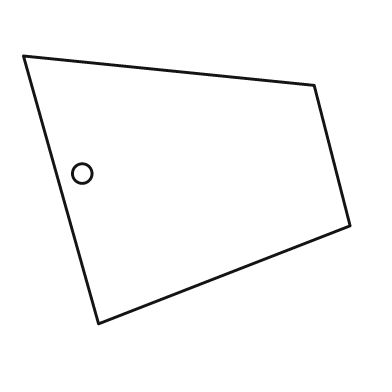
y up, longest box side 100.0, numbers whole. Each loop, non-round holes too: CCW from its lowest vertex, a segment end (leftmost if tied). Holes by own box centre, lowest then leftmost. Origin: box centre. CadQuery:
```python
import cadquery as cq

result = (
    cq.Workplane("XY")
    .moveTo(-27.0, -41.0)
    .lineTo(50.0, -11.0)
    .lineTo(39.0, 32.0)
    .lineTo(-50.0, 41.0)
    .close()
    .moveTo(-32.0, 5.0)
    .circle(3.0)
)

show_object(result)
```